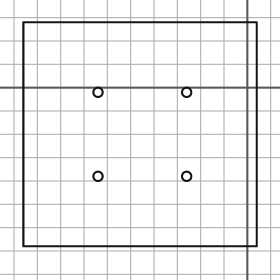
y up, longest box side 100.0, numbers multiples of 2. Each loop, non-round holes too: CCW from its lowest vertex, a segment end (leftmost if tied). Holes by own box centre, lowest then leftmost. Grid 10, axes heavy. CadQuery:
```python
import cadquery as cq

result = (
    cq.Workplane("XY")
    .moveTo(-96.0, -68.0)
    .lineTo(4.0, -68.0)
    .lineTo(4.0, 28.0)
    .lineTo(-96.0, 28.0)
    .close()
    .moveTo(-64.0, -38.0)
    .circle(2.0)
    .moveTo(-26.0, -38.0)
    .circle(2.0)
    .moveTo(-64.0, -2.0)
    .circle(2.0)
    .moveTo(-26.0, -2.0)
    .circle(2.0)
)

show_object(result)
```